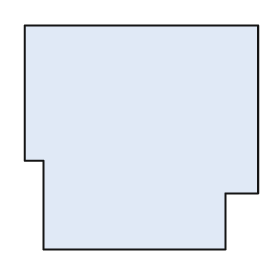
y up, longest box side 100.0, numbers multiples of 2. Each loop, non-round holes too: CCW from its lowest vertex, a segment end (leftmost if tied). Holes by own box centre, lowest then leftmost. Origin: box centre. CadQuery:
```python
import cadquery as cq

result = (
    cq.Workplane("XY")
    .moveTo(-42.0, -48.0)
    .lineTo(36.0, -48.0)
    .lineTo(36.0, -24.0)
    .lineTo(50.0, -24.0)
    .lineTo(50.0, 48.0)
    .lineTo(-50.0, 48.0)
    .lineTo(-50.0, -10.0)
    .lineTo(-42.0, -10.0)
    .close()
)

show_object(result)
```